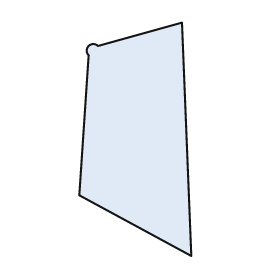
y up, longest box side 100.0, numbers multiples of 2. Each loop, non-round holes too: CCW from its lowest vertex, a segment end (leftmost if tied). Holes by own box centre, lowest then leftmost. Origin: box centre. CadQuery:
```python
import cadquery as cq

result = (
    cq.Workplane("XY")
    .moveTo(24.0, -50.0)
    .lineTo(20.0, 50.0)
    .lineTo(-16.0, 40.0)
    .threePointArc((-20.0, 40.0), (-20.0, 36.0))
    .lineTo(-24.0, -24.0)
    .close()
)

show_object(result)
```